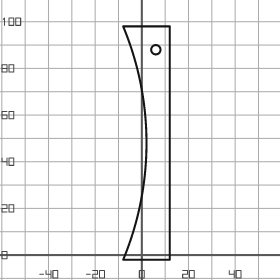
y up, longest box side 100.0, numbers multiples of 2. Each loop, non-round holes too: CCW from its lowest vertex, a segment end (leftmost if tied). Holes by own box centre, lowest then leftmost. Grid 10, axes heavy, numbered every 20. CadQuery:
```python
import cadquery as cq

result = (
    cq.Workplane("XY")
    .moveTo(-8.0, -2.0)
    .lineTo(12.0, -2.0)
    .lineTo(12.0, 98.0)
    .lineTo(-8.0, 98.0)
    .threePointArc((2.0, 48.0), (-8.0, -2.0))
    .close()
    .moveTo(6.0, 88.0)
    .circle(2.0)
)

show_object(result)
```